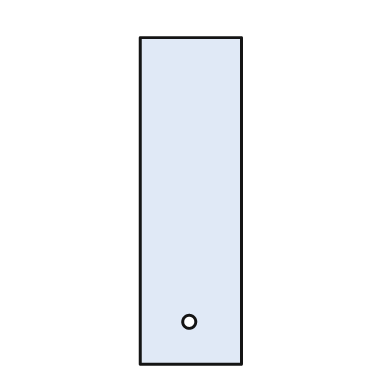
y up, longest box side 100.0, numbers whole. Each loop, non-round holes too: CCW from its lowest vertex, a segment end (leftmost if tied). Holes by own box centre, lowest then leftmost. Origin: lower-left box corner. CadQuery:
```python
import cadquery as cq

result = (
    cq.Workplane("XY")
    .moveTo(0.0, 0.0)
    .lineTo(31.0, 0.0)
    .lineTo(31.0, 100.0)
    .lineTo(0.0, 100.0)
    .close()
    .moveTo(15.0, 13.0)
    .circle(2.0)
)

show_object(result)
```